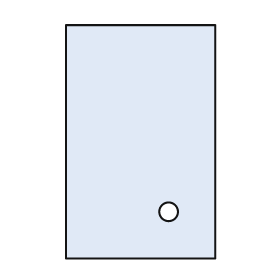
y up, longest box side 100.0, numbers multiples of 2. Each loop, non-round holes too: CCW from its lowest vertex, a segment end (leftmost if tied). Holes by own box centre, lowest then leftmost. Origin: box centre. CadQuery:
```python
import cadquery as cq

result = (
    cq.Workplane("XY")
    .moveTo(-32.0, -50.0)
    .lineTo(32.0, -50.0)
    .lineTo(32.0, 50.0)
    .lineTo(-32.0, 50.0)
    .close()
    .moveTo(12.0, -30.0)
    .circle(4.0)
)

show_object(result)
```